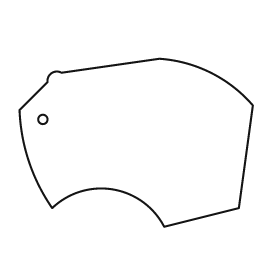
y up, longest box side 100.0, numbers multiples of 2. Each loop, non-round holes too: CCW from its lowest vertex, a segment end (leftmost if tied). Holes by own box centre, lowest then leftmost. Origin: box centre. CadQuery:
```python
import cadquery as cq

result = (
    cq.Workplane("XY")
    .moveTo(12.0, -36.0)
    .lineTo(44.0, -28.0)
    .lineTo(50.0, 16.0)
    .threePointArc((32.0, 30.0), (10.0, 36.0))
    .lineTo(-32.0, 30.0)
    .threePointArc((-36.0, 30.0), (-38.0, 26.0))
    .lineTo(-50.0, 14.0)
    .threePointArc((-46.0, -8.0), (-36.0, -28.0))
    .threePointArc((-10.0, -20.0), (12.0, -36.0))
    .close()
    .moveTo(-40.0, 10.0)
    .circle(2.0)
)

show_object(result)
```